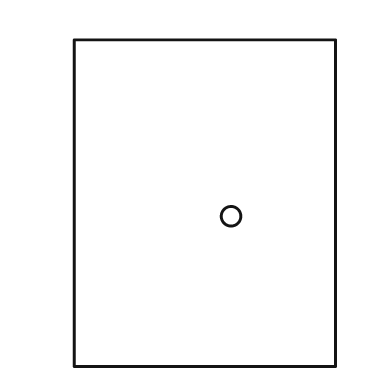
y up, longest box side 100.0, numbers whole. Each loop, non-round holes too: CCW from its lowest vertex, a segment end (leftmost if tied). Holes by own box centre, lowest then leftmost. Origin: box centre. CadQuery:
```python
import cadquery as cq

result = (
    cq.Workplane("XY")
    .moveTo(-40.0, -50.0)
    .lineTo(40.0, -50.0)
    .lineTo(40.0, 50.0)
    .lineTo(-40.0, 50.0)
    .close()
    .moveTo(8.0, -4.0)
    .circle(3.0)
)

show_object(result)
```